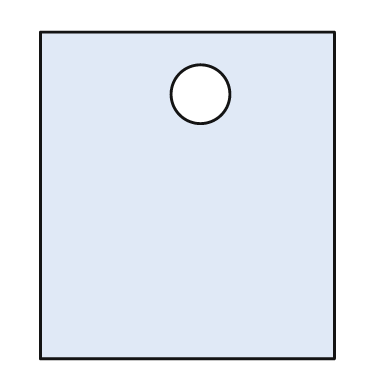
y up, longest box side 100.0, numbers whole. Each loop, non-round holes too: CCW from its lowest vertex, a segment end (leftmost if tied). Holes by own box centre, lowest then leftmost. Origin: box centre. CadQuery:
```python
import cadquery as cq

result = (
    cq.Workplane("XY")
    .moveTo(-45.0, -50.0)
    .lineTo(45.0, -50.0)
    .lineTo(45.0, 50.0)
    .lineTo(-45.0, 50.0)
    .close()
    .moveTo(4.0, 31.0)
    .circle(9.0)
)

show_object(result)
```